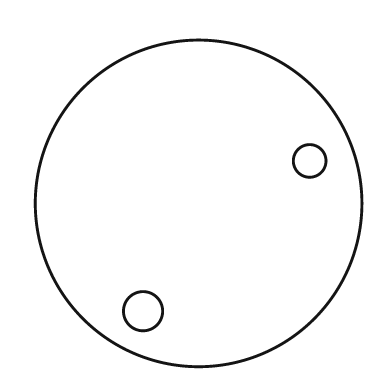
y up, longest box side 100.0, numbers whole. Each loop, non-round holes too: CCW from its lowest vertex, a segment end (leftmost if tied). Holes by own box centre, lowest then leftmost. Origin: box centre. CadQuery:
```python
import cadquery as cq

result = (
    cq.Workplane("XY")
    .moveTo(0.0, 0.0)
    .circle(50.0)
    .moveTo(-17.0, -33.0)
    .circle(6.0)
    .moveTo(34.0, 13.0)
    .circle(5.0)
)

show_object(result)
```